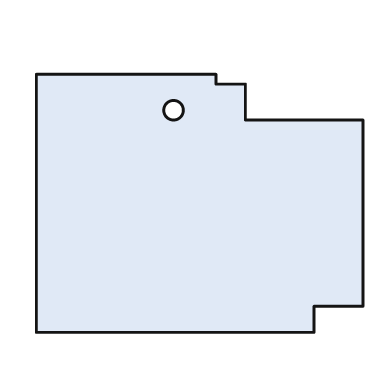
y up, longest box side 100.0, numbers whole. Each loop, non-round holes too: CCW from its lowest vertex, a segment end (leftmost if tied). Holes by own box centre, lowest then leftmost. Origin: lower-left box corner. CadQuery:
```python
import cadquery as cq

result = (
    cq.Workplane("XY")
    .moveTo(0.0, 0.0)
    .lineTo(85.0, 0.0)
    .lineTo(85.0, 8.0)
    .lineTo(100.0, 8.0)
    .lineTo(100.0, 65.0)
    .lineTo(64.0, 65.0)
    .lineTo(64.0, 76.0)
    .lineTo(55.0, 76.0)
    .lineTo(55.0, 79.0)
    .lineTo(0.0, 79.0)
    .close()
    .moveTo(42.0, 68.0)
    .circle(3.0)
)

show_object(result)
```